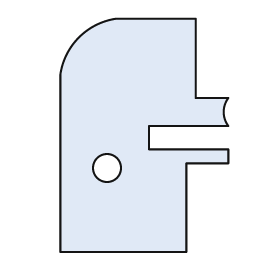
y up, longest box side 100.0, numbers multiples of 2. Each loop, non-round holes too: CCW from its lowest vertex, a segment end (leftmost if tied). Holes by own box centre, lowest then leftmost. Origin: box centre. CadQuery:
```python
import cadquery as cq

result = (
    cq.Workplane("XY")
    .moveTo(-36.0, -50.0)
    .lineTo(18.0, -50.0)
    .lineTo(18.0, -12.0)
    .lineTo(36.0, -12.0)
    .lineTo(36.0, -6.0)
    .lineTo(2.0, -6.0)
    .lineTo(2.0, 4.0)
    .lineTo(36.0, 4.0)
    .threePointArc((34.0, 10.0), (36.0, 16.0))
    .lineTo(22.0, 16.0)
    .lineTo(22.0, 50.0)
    .lineTo(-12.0, 50.0)
    .threePointArc((-28.0, 42.0), (-36.0, 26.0))
    .close()
    .moveTo(-16.0, -14.0)
    .circle(6.0)
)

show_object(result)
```